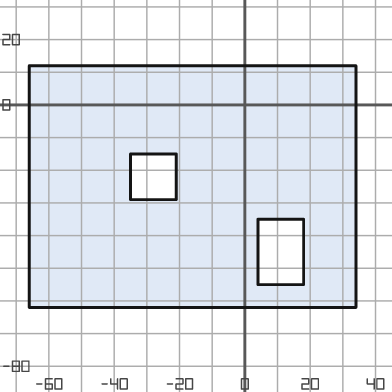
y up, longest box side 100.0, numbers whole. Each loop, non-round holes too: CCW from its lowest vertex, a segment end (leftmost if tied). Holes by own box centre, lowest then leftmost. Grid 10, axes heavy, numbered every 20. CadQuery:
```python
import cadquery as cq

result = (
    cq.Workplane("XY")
    .moveTo(-66.0, -62.0)
    .lineTo(34.0, -62.0)
    .lineTo(34.0, 12.0)
    .lineTo(-66.0, 12.0)
    .close()
    .moveTo(4.0, -55.0)
    .lineTo(18.0, -55.0)
    .lineTo(18.0, -35.0)
    .lineTo(4.0, -35.0)
    .close()
    .moveTo(-35.0, -29.0)
    .lineTo(-21.0, -29.0)
    .lineTo(-21.0, -15.0)
    .lineTo(-35.0, -15.0)
    .close()
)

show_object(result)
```